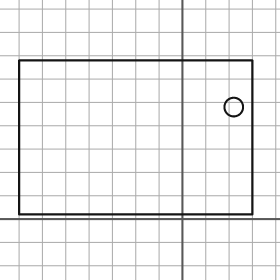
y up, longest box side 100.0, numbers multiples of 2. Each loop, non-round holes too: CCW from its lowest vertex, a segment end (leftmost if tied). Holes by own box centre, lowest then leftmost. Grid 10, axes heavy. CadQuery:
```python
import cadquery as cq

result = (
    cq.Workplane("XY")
    .moveTo(-70.0, 2.0)
    .lineTo(30.0, 2.0)
    .lineTo(30.0, 68.0)
    .lineTo(-70.0, 68.0)
    .close()
    .moveTo(22.0, 48.0)
    .circle(4.0)
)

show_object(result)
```